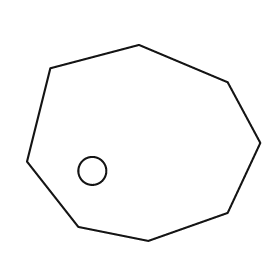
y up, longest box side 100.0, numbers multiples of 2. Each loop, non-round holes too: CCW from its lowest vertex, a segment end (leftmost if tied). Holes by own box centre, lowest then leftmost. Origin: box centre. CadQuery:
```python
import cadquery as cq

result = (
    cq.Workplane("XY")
    .moveTo(2.0, -42.0)
    .lineTo(36.0, -30.0)
    .lineTo(50.0, 0.0)
    .lineTo(36.0, 26.0)
    .lineTo(-2.0, 42.0)
    .lineTo(-40.0, 32.0)
    .lineTo(-50.0, -8.0)
    .lineTo(-28.0, -36.0)
    .close()
    .moveTo(-22.0, -12.0)
    .circle(6.0)
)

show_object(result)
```